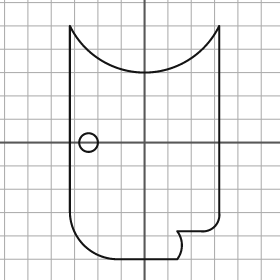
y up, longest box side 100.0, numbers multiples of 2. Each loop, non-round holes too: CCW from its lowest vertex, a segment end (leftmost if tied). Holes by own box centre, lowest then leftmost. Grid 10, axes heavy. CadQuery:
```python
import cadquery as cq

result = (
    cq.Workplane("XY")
    .moveTo(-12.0, -50.0)
    .lineTo(14.0, -50.0)
    .threePointArc((16.0, -44.0), (14.0, -38.0))
    .lineTo(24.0, -38.0)
    .threePointArc((30.0, -36.0), (32.0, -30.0))
    .lineTo(32.0, 50.0)
    .threePointArc((0.0, 30.0), (-32.0, 50.0))
    .lineTo(-32.0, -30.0)
    .threePointArc((-26.0, -44.0), (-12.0, -50.0))
    .close()
    .moveTo(-24.0, 0.0)
    .circle(4.0)
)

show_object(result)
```